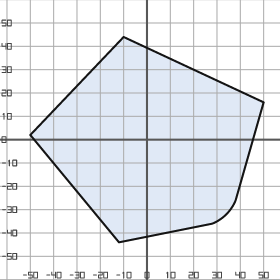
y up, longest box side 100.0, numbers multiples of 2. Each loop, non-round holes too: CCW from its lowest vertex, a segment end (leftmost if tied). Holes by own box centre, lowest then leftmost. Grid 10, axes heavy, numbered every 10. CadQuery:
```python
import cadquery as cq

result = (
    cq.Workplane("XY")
    .moveTo(-12.0, -44.0)
    .lineTo(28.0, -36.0)
    .threePointArc((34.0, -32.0), (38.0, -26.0))
    .lineTo(50.0, 16.0)
    .lineTo(-10.0, 44.0)
    .lineTo(-50.0, 2.0)
    .close()
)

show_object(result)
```